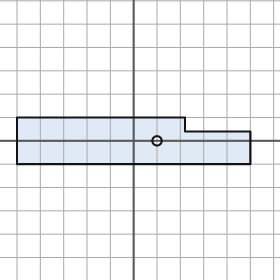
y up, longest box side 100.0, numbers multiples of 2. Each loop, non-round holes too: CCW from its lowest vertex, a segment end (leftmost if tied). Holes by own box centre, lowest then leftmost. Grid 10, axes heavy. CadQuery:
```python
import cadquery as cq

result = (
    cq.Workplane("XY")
    .moveTo(-50.0, -10.0)
    .lineTo(50.0, -10.0)
    .lineTo(50.0, 4.0)
    .lineTo(22.0, 4.0)
    .lineTo(22.0, 10.0)
    .lineTo(-50.0, 10.0)
    .close()
    .moveTo(10.0, 0.0)
    .circle(2.0)
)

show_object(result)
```